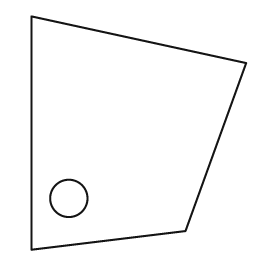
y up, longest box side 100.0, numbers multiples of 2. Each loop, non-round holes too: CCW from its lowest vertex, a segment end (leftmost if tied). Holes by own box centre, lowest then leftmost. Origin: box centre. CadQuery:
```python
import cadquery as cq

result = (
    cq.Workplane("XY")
    .moveTo(-46.0, -50.0)
    .lineTo(20.0, -42.0)
    .lineTo(46.0, 30.0)
    .lineTo(-46.0, 50.0)
    .close()
    .moveTo(-30.0, -28.0)
    .circle(8.0)
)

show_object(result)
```